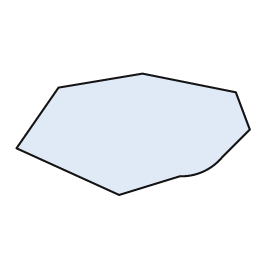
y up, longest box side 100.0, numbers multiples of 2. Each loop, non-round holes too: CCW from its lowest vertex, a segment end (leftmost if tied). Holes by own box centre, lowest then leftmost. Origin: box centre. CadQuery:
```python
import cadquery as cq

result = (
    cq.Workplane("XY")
    .moveTo(-6.0, -26.0)
    .lineTo(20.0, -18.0)
    .threePointArc((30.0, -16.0), (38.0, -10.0))
    .lineTo(50.0, 2.0)
    .lineTo(44.0, 18.0)
    .lineTo(4.0, 26.0)
    .lineTo(-32.0, 20.0)
    .lineTo(-50.0, -6.0)
    .close()
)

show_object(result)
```